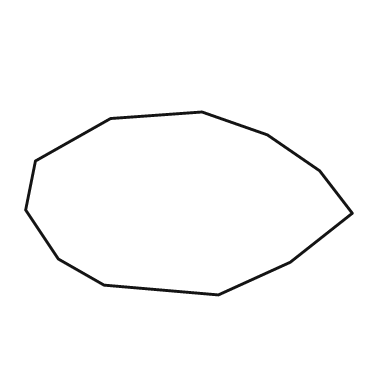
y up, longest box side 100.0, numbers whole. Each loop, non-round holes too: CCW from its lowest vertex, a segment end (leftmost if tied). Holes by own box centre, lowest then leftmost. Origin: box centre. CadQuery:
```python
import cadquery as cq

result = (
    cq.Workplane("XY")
    .moveTo(9.0, -28.0)
    .lineTo(31.0, -18.0)
    .lineTo(50.0, -3.0)
    .lineTo(40.0, 10.0)
    .lineTo(24.0, 21.0)
    .lineTo(4.0, 28.0)
    .lineTo(-24.0, 26.0)
    .lineTo(-47.0, 13.0)
    .lineTo(-50.0, -2.0)
    .lineTo(-40.0, -17.0)
    .lineTo(-26.0, -25.0)
    .close()
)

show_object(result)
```